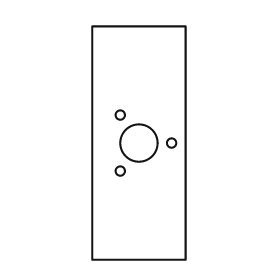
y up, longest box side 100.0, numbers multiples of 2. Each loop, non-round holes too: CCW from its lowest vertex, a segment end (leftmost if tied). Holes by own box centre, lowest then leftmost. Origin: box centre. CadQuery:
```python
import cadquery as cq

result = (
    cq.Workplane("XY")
    .moveTo(-20.0, -50.0)
    .lineTo(20.0, -50.0)
    .lineTo(20.0, 50.0)
    .lineTo(-20.0, 50.0)
    .close()
    .moveTo(-8.0, -12.0)
    .circle(2.0)
    .moveTo(0.0, 0.0)
    .circle(8.0)
    .moveTo(14.0, 0.0)
    .circle(2.0)
    .moveTo(-8.0, 12.0)
    .circle(2.0)
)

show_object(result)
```